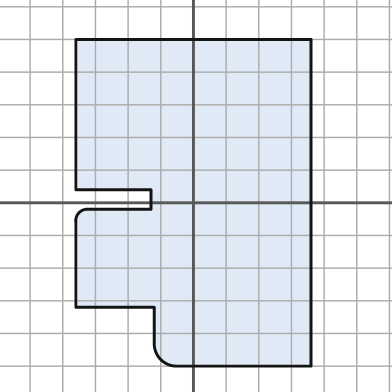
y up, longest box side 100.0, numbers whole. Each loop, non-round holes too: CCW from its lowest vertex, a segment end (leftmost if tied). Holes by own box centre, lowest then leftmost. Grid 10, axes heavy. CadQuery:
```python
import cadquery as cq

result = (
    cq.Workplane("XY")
    .moveTo(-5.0, -50.0)
    .lineTo(36.0, -50.0)
    .lineTo(36.0, 50.0)
    .lineTo(-36.0, 50.0)
    .lineTo(-36.0, 4.0)
    .lineTo(-13.0, 4.0)
    .lineTo(-13.0, -2.0)
    .lineTo(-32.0, -2.0)
    .threePointArc((-35.0, -3.0), (-36.0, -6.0))
    .lineTo(-36.0, -32.0)
    .lineTo(-12.0, -32.0)
    .lineTo(-12.0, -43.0)
    .threePointArc((-10.0, -48.0), (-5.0, -50.0))
    .close()
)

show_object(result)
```